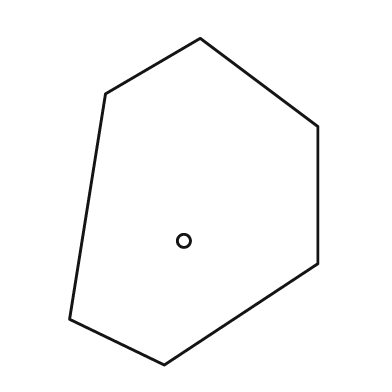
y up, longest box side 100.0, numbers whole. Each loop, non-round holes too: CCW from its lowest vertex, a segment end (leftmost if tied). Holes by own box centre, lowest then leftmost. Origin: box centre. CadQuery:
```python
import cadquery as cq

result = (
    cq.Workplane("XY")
    .moveTo(-9.0, -50.0)
    .lineTo(38.0, -19.0)
    .lineTo(38.0, 23.0)
    .lineTo(2.0, 50.0)
    .lineTo(-27.0, 33.0)
    .lineTo(-38.0, -36.0)
    .close()
    .moveTo(-3.0, -12.0)
    .circle(2.0)
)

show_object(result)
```